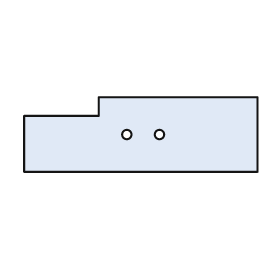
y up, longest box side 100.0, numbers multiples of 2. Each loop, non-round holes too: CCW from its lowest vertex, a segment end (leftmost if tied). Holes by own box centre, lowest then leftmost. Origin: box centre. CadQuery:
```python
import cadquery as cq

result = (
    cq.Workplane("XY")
    .moveTo(-50.0, -16.0)
    .lineTo(50.0, -16.0)
    .lineTo(50.0, 16.0)
    .lineTo(-18.0, 16.0)
    .lineTo(-18.0, 8.0)
    .lineTo(-50.0, 8.0)
    .close()
    .moveTo(-6.0, 0.0)
    .circle(2.0)
    .moveTo(8.0, 0.0)
    .circle(2.0)
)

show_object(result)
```